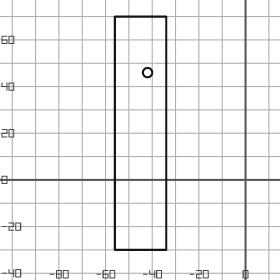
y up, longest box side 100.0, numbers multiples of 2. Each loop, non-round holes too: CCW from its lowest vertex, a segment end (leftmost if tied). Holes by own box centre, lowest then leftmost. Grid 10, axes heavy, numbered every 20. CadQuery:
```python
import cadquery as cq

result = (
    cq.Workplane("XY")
    .moveTo(-56.0, -30.0)
    .lineTo(-34.0, -30.0)
    .lineTo(-34.0, 70.0)
    .lineTo(-56.0, 70.0)
    .close()
    .moveTo(-42.0, 46.0)
    .circle(2.0)
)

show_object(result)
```